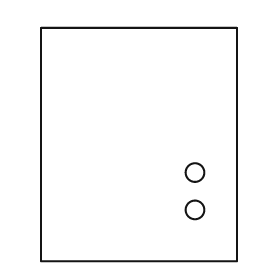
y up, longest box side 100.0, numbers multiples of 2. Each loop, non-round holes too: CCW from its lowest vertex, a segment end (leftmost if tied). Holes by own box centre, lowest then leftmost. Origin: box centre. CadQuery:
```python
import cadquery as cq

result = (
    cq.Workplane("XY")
    .moveTo(-42.0, -50.0)
    .lineTo(42.0, -50.0)
    .lineTo(42.0, 50.0)
    .lineTo(-42.0, 50.0)
    .close()
    .moveTo(24.0, -28.0)
    .circle(4.0)
    .moveTo(24.0, -12.0)
    .circle(4.0)
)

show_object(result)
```